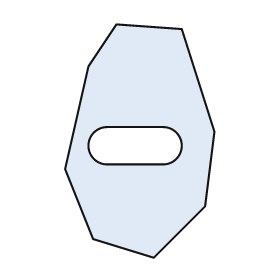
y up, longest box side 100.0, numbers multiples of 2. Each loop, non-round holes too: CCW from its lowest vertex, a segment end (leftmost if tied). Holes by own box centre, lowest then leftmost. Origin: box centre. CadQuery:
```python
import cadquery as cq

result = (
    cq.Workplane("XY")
    .moveTo(6.0, -50.0)
    .lineTo(28.0, -28.0)
    .lineTo(32.0, 4.0)
    .lineTo(18.0, 48.0)
    .lineTo(-10.0, 50.0)
    .lineTo(-22.0, 32.0)
    .lineTo(-32.0, -12.0)
    .lineTo(-20.0, -42.0)
    .close()
    .moveTo(-14.0, -10.0)
    .lineTo(10.0, -10.0)
    .threePointArc((18.0, -2.0), (10.0, 6.0))
    .lineTo(-14.0, 6.0)
    .threePointArc((-22.0, -2.0), (-14.0, -10.0))
    .close()
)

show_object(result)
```